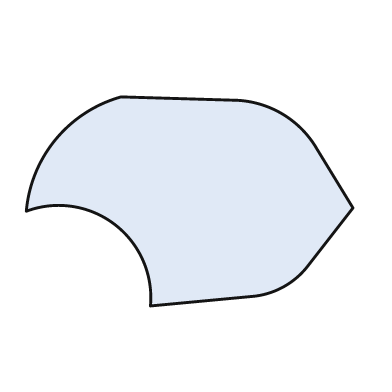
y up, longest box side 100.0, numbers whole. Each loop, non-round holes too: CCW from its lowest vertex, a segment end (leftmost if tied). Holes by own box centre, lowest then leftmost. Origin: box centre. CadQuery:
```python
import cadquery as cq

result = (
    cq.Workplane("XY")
    .moveTo(-12.0, -32.0)
    .lineTo(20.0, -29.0)
    .threePointArc((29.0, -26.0), (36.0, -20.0))
    .lineTo(50.0, -2.0)
    .lineTo(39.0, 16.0)
    .threePointArc((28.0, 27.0), (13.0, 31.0))
    .lineTo(-21.0, 32.0)
    .threePointArc((-41.0, 19.0), (-50.0, -3.0))
    .threePointArc((-23.0, -7.0), (-12.0, -32.0))
    .close()
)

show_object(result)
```